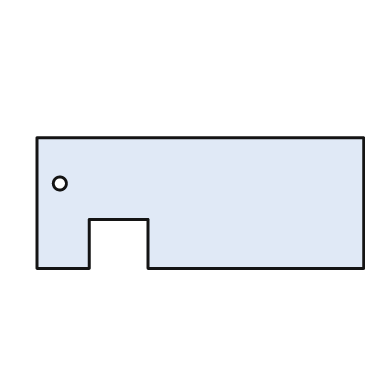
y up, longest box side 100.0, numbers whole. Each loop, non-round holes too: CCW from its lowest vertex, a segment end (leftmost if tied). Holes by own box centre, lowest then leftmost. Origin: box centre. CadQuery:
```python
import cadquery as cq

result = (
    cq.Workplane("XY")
    .moveTo(-50.0, -20.0)
    .lineTo(-34.0, -20.0)
    .lineTo(-34.0, -5.0)
    .lineTo(-16.0, -5.0)
    .lineTo(-16.0, -20.0)
    .lineTo(50.0, -20.0)
    .lineTo(50.0, 20.0)
    .lineTo(-50.0, 20.0)
    .close()
    .moveTo(-43.0, 6.0)
    .circle(2.0)
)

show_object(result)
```